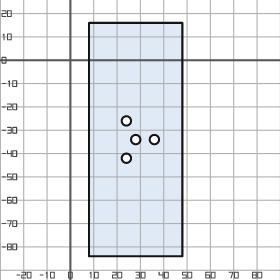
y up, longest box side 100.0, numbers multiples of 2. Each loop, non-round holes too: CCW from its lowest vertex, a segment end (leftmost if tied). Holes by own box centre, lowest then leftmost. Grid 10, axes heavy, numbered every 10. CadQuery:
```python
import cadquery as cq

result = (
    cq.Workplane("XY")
    .moveTo(8.0, -84.0)
    .lineTo(48.0, -84.0)
    .lineTo(48.0, 16.0)
    .lineTo(8.0, 16.0)
    .close()
    .moveTo(24.0, -42.0)
    .circle(2.0)
    .moveTo(28.0, -34.0)
    .circle(2.0)
    .moveTo(36.0, -34.0)
    .circle(2.0)
    .moveTo(24.0, -26.0)
    .circle(2.0)
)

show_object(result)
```